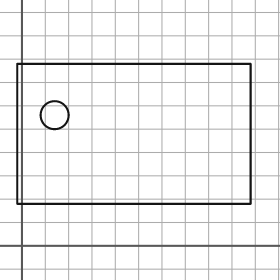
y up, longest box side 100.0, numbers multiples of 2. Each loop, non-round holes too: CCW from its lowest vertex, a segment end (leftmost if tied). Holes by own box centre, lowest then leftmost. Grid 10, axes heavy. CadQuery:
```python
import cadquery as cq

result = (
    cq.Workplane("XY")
    .moveTo(-2.0, 18.0)
    .lineTo(98.0, 18.0)
    .lineTo(98.0, 78.0)
    .lineTo(-2.0, 78.0)
    .close()
    .moveTo(14.0, 56.0)
    .circle(6.0)
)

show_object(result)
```